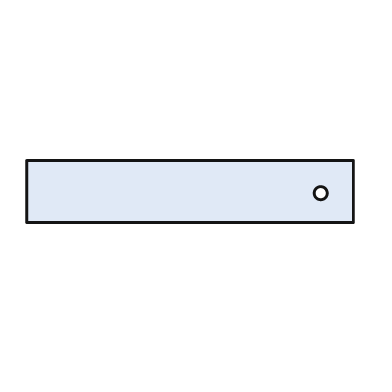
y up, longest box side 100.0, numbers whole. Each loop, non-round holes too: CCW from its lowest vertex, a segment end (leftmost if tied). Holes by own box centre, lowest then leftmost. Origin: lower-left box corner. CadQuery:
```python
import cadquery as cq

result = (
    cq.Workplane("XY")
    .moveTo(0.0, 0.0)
    .lineTo(100.0, 0.0)
    .lineTo(100.0, 19.0)
    .lineTo(0.0, 19.0)
    .close()
    .moveTo(90.0, 9.0)
    .circle(2.0)
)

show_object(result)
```